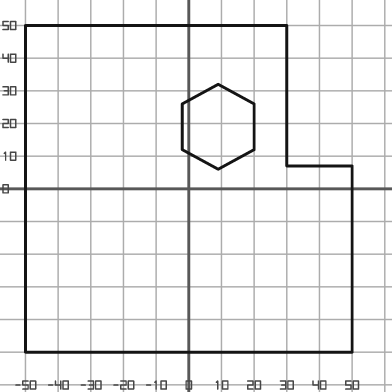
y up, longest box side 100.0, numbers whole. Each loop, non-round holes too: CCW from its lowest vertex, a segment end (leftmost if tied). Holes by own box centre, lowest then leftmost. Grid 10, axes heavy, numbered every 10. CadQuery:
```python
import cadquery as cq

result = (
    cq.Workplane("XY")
    .moveTo(-50.0, -50.0)
    .lineTo(50.0, -50.0)
    .lineTo(50.0, 7.0)
    .lineTo(30.0, 7.0)
    .lineTo(30.0, 50.0)
    .lineTo(-50.0, 50.0)
    .close()
    .moveTo(9.0, 6.0)
    .lineTo(20.0, 12.0)
    .lineTo(20.0, 26.0)
    .lineTo(9.0, 32.0)
    .lineTo(-2.0, 26.0)
    .lineTo(-2.0, 12.0)
    .close()
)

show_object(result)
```